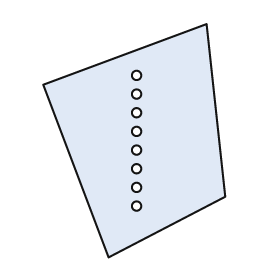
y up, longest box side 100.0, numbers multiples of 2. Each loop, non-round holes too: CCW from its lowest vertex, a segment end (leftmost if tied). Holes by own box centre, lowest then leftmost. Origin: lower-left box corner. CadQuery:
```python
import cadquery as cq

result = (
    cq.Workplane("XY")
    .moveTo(28.0, 0.0)
    .lineTo(78.0, 26.0)
    .lineTo(70.0, 100.0)
    .lineTo(0.0, 74.0)
    .close()
    .moveTo(40.0, 22.0)
    .circle(2.0)
    .moveTo(40.0, 30.0)
    .circle(2.0)
    .moveTo(40.0, 38.0)
    .circle(2.0)
    .moveTo(40.0, 46.0)
    .circle(2.0)
    .moveTo(40.0, 54.0)
    .circle(2.0)
    .moveTo(40.0, 62.0)
    .circle(2.0)
    .moveTo(40.0, 70.0)
    .circle(2.0)
    .moveTo(40.0, 78.0)
    .circle(2.0)
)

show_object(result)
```